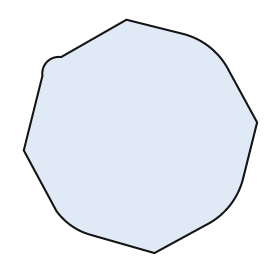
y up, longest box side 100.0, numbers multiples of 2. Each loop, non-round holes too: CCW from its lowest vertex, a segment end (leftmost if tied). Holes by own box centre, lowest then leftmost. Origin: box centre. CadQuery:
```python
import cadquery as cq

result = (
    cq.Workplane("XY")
    .moveTo(6.0, -50.0)
    .lineTo(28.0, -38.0)
    .threePointArc((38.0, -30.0), (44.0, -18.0))
    .lineTo(50.0, 6.0)
    .lineTo(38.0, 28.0)
    .threePointArc((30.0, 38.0), (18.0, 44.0))
    .lineTo(-6.0, 50.0)
    .lineTo(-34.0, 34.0)
    .threePointArc((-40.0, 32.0), (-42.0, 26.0))
    .lineTo(-50.0, -6.0)
    .lineTo(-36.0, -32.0)
    .threePointArc((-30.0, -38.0), (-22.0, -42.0))
    .close()
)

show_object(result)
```